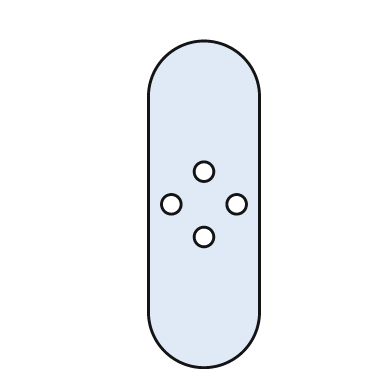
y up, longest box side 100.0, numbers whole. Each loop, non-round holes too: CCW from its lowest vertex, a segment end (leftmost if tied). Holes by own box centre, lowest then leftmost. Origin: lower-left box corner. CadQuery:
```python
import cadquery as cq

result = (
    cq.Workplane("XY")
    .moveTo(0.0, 17.0)
    .threePointArc((17.0, 0.0), (34.0, 17.0))
    .lineTo(34.0, 83.0)
    .threePointArc((17.0, 100.0), (0.0, 83.0))
    .close()
    .moveTo(17.0, 40.0)
    .circle(3.0)
    .moveTo(7.0, 50.0)
    .circle(3.0)
    .moveTo(27.0, 50.0)
    .circle(3.0)
    .moveTo(17.0, 60.0)
    .circle(3.0)
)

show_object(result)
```